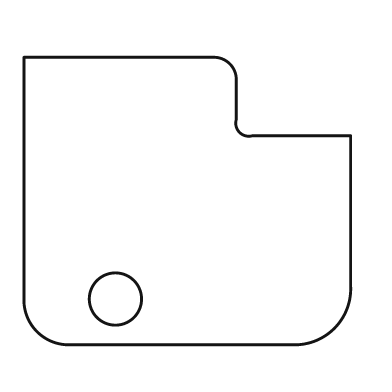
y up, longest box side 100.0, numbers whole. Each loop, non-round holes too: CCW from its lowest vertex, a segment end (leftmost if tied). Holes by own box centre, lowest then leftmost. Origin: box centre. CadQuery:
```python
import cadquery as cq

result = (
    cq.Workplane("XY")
    .moveTo(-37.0, -44.0)
    .lineTo(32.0, -44.0)
    .threePointArc((45.0, -39.0), (50.0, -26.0))
    .lineTo(50.0, 20.0)
    .lineTo(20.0, 20.0)
    .threePointArc((16.0, 21.0), (15.0, 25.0))
    .lineTo(15.0, 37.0)
    .threePointArc((13.0, 42.0), (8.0, 44.0))
    .lineTo(-50.0, 44.0)
    .lineTo(-50.0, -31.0)
    .threePointArc((-46.0, -40.0), (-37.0, -44.0))
    .close()
    .moveTo(-22.0, -30.0)
    .circle(8.0)
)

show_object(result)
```